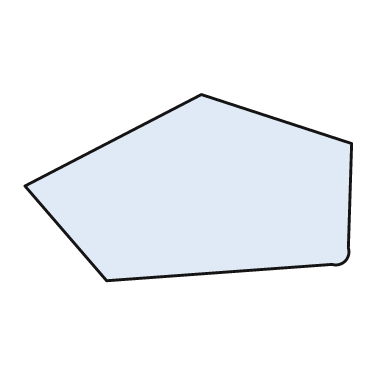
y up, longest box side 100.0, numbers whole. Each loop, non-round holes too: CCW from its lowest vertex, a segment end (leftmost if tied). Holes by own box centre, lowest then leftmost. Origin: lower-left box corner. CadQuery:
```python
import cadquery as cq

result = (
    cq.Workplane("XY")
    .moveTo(25.0, 0.0)
    .lineTo(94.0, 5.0)
    .threePointArc((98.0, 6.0), (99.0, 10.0))
    .lineTo(100.0, 42.0)
    .lineTo(54.0, 57.0)
    .lineTo(0.0, 29.0)
    .close()
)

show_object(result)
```